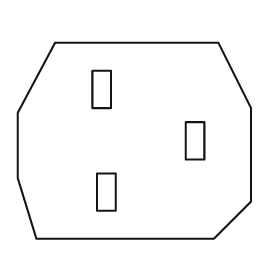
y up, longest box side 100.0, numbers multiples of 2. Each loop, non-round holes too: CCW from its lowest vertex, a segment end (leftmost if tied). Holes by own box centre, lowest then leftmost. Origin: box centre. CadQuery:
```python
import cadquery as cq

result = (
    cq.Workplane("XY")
    .moveTo(-42.0, -42.0)
    .lineTo(34.0, -42.0)
    .lineTo(50.0, -26.0)
    .lineTo(50.0, 14.0)
    .lineTo(36.0, 42.0)
    .lineTo(-34.0, 42.0)
    .lineTo(-50.0, 12.0)
    .lineTo(-50.0, -16.0)
    .close()
    .moveTo(-16.0, -30.0)
    .lineTo(-8.0, -30.0)
    .lineTo(-8.0, -14.0)
    .lineTo(-16.0, -14.0)
    .close()
    .moveTo(22.0, -8.0)
    .lineTo(30.0, -8.0)
    .lineTo(30.0, 8.0)
    .lineTo(22.0, 8.0)
    .close()
    .moveTo(-18.0, 14.0)
    .lineTo(-10.0, 14.0)
    .lineTo(-10.0, 30.0)
    .lineTo(-18.0, 30.0)
    .close()
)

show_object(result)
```